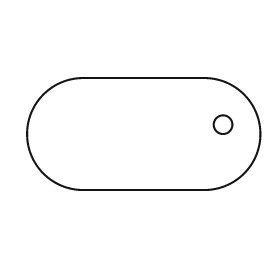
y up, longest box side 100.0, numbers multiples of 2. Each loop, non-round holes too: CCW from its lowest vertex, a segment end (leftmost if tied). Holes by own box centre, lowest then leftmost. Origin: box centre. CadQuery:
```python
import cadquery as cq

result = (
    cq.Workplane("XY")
    .moveTo(-26.0, -24.0)
    .lineTo(26.0, -24.0)
    .threePointArc((50.0, 0.0), (26.0, 24.0))
    .lineTo(-26.0, 24.0)
    .threePointArc((-50.0, 0.0), (-26.0, -24.0))
    .close()
    .moveTo(34.0, 4.0)
    .circle(4.0)
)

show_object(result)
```